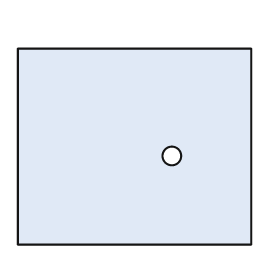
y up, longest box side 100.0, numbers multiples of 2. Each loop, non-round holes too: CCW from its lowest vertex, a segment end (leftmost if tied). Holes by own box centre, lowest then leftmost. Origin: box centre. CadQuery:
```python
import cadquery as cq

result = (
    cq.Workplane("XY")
    .moveTo(-50.0, -42.0)
    .lineTo(50.0, -42.0)
    .lineTo(50.0, 42.0)
    .lineTo(-50.0, 42.0)
    .close()
    .moveTo(16.0, -4.0)
    .circle(4.0)
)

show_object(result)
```